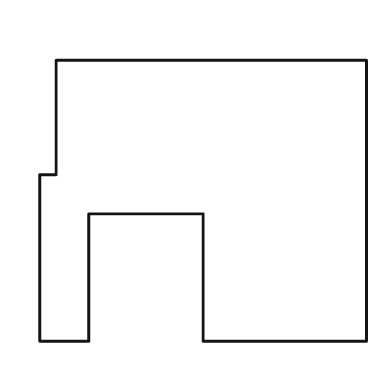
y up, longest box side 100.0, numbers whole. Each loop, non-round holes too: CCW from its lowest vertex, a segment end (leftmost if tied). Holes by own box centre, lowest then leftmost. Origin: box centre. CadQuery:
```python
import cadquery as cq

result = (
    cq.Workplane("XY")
    .moveTo(-50.0, -43.0)
    .lineTo(-35.0, -43.0)
    .lineTo(-35.0, -4.0)
    .lineTo(0.0, -4.0)
    .lineTo(0.0, -43.0)
    .lineTo(50.0, -43.0)
    .lineTo(50.0, 43.0)
    .lineTo(-45.0, 43.0)
    .lineTo(-45.0, 8.0)
    .lineTo(-50.0, 8.0)
    .close()
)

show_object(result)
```